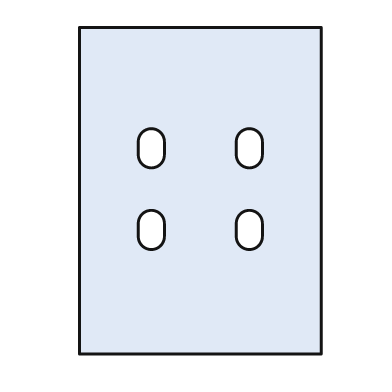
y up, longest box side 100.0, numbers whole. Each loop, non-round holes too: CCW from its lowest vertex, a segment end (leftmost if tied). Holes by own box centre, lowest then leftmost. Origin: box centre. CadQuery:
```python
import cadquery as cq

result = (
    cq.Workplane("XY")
    .moveTo(-37.0, -50.0)
    .lineTo(37.0, -50.0)
    .lineTo(37.0, 50.0)
    .lineTo(-37.0, 50.0)
    .close()
    .moveTo(-19.0, -14.0)
    .threePointArc((-15.0, -18.0), (-11.0, -14.0))
    .lineTo(-11.0, -10.0)
    .threePointArc((-15.0, -6.0), (-19.0, -10.0))
    .close()
    .moveTo(11.0, -14.0)
    .threePointArc((15.0, -18.0), (19.0, -14.0))
    .lineTo(19.0, -10.0)
    .threePointArc((15.0, -6.0), (11.0, -10.0))
    .close()
    .moveTo(-19.0, 11.0)
    .threePointArc((-15.0, 7.0), (-11.0, 11.0))
    .lineTo(-11.0, 15.0)
    .threePointArc((-15.0, 19.0), (-19.0, 15.0))
    .close()
    .moveTo(11.0, 11.0)
    .threePointArc((15.0, 7.0), (19.0, 11.0))
    .lineTo(19.0, 15.0)
    .threePointArc((15.0, 19.0), (11.0, 15.0))
    .close()
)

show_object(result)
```